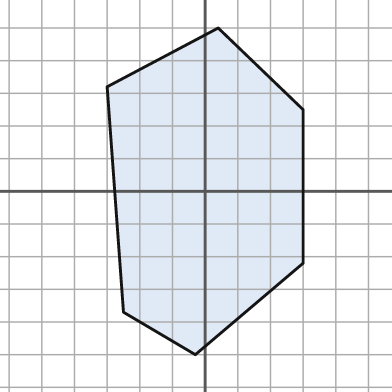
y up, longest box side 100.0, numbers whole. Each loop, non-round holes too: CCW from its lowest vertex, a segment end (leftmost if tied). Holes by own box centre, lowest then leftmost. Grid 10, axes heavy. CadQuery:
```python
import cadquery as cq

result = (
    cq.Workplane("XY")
    .moveTo(-3.0, -50.0)
    .lineTo(30.0, -22.0)
    .lineTo(30.0, 25.0)
    .lineTo(4.0, 50.0)
    .lineTo(-30.0, 32.0)
    .lineTo(-25.0, -37.0)
    .close()
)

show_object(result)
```